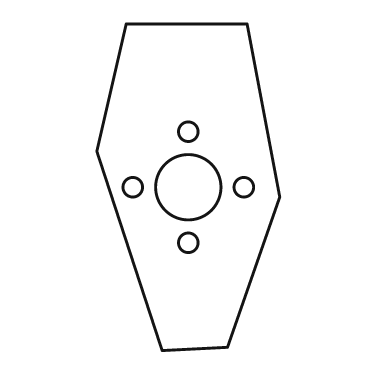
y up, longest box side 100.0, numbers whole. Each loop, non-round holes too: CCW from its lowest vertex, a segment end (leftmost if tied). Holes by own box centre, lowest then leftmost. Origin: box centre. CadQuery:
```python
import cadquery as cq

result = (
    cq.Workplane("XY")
    .moveTo(-8.0, -50.0)
    .lineTo(12.0, -49.0)
    .lineTo(28.0, -3.0)
    .lineTo(18.0, 50.0)
    .lineTo(-19.0, 50.0)
    .lineTo(-28.0, 11.0)
    .close()
    .moveTo(0.0, -17.0)
    .circle(3.0)
    .moveTo(-17.0, 0.0)
    .circle(3.0)
    .moveTo(0.0, 0.0)
    .circle(10.0)
    .moveTo(17.0, 0.0)
    .circle(3.0)
    .moveTo(0.0, 17.0)
    .circle(3.0)
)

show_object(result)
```